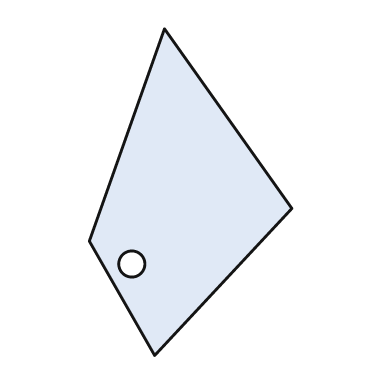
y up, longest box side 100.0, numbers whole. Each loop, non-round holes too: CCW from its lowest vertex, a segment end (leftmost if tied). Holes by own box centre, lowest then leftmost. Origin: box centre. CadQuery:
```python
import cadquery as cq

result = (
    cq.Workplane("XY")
    .moveTo(-11.0, -50.0)
    .lineTo(31.0, -5.0)
    .lineTo(-8.0, 50.0)
    .lineTo(-31.0, -15.0)
    .close()
    .moveTo(-18.0, -22.0)
    .circle(4.0)
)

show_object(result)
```